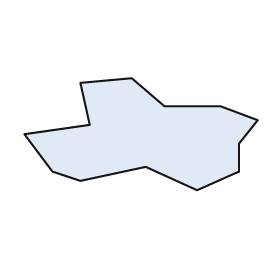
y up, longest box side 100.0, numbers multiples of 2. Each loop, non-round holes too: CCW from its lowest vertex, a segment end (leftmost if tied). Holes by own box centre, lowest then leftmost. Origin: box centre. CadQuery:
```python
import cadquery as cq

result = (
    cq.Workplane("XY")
    .moveTo(24.0, -24.0)
    .lineTo(42.0, -16.0)
    .lineTo(42.0, -4.0)
    .lineTo(50.0, 6.0)
    .lineTo(34.0, 12.0)
    .lineTo(10.0, 12.0)
    .lineTo(-4.0, 24.0)
    .lineTo(-26.0, 22.0)
    .lineTo(-22.0, 4.0)
    .lineTo(-50.0, 0.0)
    .lineTo(-38.0, -16.0)
    .lineTo(-26.0, -20.0)
    .lineTo(2.0, -14.0)
    .close()
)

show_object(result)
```